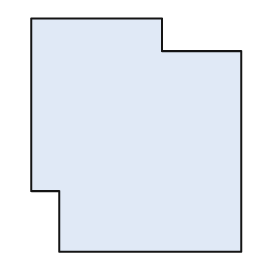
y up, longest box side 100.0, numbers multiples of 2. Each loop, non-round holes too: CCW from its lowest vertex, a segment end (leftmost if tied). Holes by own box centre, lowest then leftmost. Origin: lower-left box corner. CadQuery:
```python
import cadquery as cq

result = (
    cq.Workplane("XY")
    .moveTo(12.0, 0.0)
    .lineTo(90.0, 0.0)
    .lineTo(90.0, 86.0)
    .lineTo(56.0, 86.0)
    .lineTo(56.0, 100.0)
    .lineTo(0.0, 100.0)
    .lineTo(0.0, 26.0)
    .lineTo(12.0, 26.0)
    .close()
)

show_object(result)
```